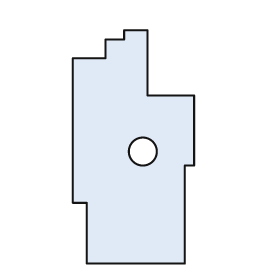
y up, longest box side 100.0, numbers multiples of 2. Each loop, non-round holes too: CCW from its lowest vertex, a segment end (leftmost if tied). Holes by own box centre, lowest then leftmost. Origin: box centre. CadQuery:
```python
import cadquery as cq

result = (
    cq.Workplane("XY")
    .moveTo(-20.0, -50.0)
    .lineTo(22.0, -50.0)
    .lineTo(22.0, -8.0)
    .lineTo(26.0, -8.0)
    .lineTo(26.0, 22.0)
    .lineTo(6.0, 22.0)
    .lineTo(6.0, 50.0)
    .lineTo(-4.0, 50.0)
    .lineTo(-4.0, 46.0)
    .lineTo(-12.0, 46.0)
    .lineTo(-12.0, 38.0)
    .lineTo(-26.0, 38.0)
    .lineTo(-26.0, -24.0)
    .lineTo(-20.0, -24.0)
    .close()
    .moveTo(4.0, -2.0)
    .circle(6.0)
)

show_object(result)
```